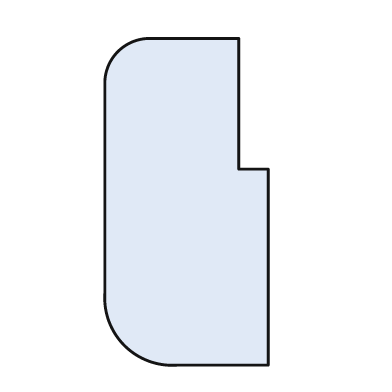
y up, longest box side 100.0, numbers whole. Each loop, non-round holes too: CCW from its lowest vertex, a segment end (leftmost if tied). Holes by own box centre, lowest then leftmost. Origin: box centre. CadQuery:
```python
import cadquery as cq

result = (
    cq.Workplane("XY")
    .moveTo(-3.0, -50.0)
    .lineTo(25.0, -50.0)
    .lineTo(25.0, 10.0)
    .lineTo(16.0, 10.0)
    .lineTo(16.0, 50.0)
    .lineTo(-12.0, 50.0)
    .threePointArc((-21.0, 46.0), (-25.0, 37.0))
    .lineTo(-25.0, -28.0)
    .threePointArc((-19.0, -44.0), (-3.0, -50.0))
    .close()
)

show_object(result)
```